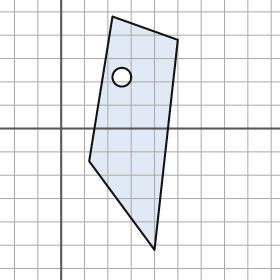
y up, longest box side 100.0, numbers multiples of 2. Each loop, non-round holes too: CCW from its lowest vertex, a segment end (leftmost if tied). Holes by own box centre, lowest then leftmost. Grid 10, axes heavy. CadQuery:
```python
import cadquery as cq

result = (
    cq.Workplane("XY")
    .moveTo(40.0, -52.0)
    .lineTo(50.0, 38.0)
    .lineTo(22.0, 48.0)
    .lineTo(12.0, -14.0)
    .close()
    .moveTo(26.0, 22.0)
    .circle(4.0)
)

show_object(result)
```